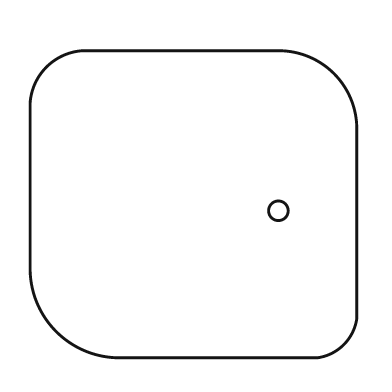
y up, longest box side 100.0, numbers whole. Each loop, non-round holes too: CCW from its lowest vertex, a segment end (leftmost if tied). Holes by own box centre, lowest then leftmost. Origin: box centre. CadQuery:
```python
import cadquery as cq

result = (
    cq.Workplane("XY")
    .moveTo(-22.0, -47.0)
    .lineTo(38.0, -47.0)
    .threePointArc((46.0, -43.0), (50.0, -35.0))
    .lineTo(50.0, 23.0)
    .threePointArc((43.0, 40.0), (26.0, 47.0))
    .lineTo(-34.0, 47.0)
    .threePointArc((-45.0, 42.0), (-50.0, 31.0))
    .lineTo(-50.0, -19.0)
    .threePointArc((-42.0, -39.0), (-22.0, -47.0))
    .close()
    .moveTo(26.0, -2.0)
    .circle(3.0)
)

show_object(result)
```